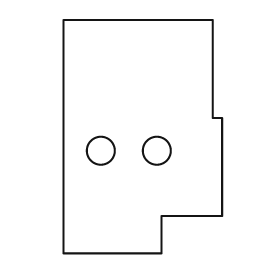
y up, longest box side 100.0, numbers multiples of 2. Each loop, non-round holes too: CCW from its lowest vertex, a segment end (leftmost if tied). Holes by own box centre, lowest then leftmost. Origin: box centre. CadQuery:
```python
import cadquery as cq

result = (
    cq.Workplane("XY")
    .moveTo(-34.0, -50.0)
    .lineTo(8.0, -50.0)
    .lineTo(8.0, -34.0)
    .lineTo(34.0, -34.0)
    .lineTo(34.0, 8.0)
    .lineTo(30.0, 8.0)
    .lineTo(30.0, 50.0)
    .lineTo(-34.0, 50.0)
    .close()
    .moveTo(-18.0, -6.0)
    .circle(6.0)
    .moveTo(6.0, -6.0)
    .circle(6.0)
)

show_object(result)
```